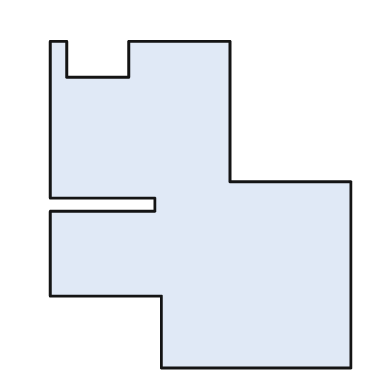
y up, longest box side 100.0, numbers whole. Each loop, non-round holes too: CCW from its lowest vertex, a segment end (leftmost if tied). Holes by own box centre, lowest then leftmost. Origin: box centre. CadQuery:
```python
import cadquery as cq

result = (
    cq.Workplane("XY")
    .moveTo(-12.0, -50.0)
    .lineTo(46.0, -50.0)
    .lineTo(46.0, 7.0)
    .lineTo(9.0, 7.0)
    .lineTo(9.0, 50.0)
    .lineTo(-22.0, 50.0)
    .lineTo(-22.0, 39.0)
    .lineTo(-41.0, 39.0)
    .lineTo(-41.0, 50.0)
    .lineTo(-46.0, 50.0)
    .lineTo(-46.0, 2.0)
    .lineTo(-14.0, 2.0)
    .lineTo(-14.0, -2.0)
    .lineTo(-46.0, -2.0)
    .lineTo(-46.0, -28.0)
    .lineTo(-12.0, -28.0)
    .close()
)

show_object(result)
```